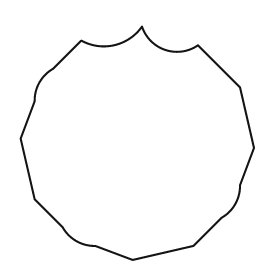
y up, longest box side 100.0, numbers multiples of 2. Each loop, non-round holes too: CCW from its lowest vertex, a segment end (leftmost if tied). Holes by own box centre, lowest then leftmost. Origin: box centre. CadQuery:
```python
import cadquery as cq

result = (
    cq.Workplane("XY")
    .moveTo(-2.0, -50.0)
    .lineTo(24.0, -44.0)
    .lineTo(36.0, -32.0)
    .threePointArc((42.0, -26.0), (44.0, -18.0))
    .lineTo(50.0, -2.0)
    .lineTo(44.0, 24.0)
    .lineTo(26.0, 42.0)
    .threePointArc((12.0, 40.0), (2.0, 50.0))
    .threePointArc((-10.0, 42.0), (-24.0, 44.0))
    .lineTo(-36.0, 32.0)
    .threePointArc((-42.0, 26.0), (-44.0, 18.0))
    .lineTo(-50.0, 2.0)
    .lineTo(-44.0, -24.0)
    .lineTo(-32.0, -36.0)
    .threePointArc((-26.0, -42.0), (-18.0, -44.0))
    .close()
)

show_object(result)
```